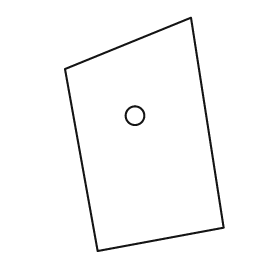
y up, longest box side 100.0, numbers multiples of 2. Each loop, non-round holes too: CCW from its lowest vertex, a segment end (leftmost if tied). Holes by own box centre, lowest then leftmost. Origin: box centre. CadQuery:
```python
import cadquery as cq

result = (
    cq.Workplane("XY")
    .moveTo(-20.0, -50.0)
    .lineTo(34.0, -40.0)
    .lineTo(20.0, 50.0)
    .lineTo(-34.0, 28.0)
    .close()
    .moveTo(-4.0, 8.0)
    .circle(4.0)
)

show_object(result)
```